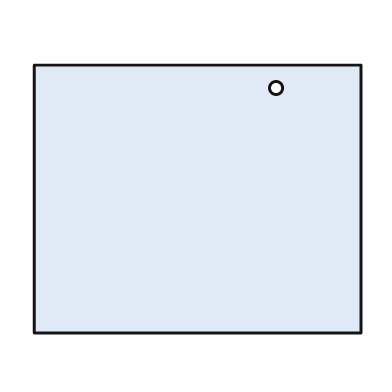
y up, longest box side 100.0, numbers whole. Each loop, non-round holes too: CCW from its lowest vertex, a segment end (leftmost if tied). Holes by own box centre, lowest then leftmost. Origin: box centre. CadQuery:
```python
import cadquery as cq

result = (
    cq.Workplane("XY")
    .moveTo(-50.0, -41.0)
    .lineTo(50.0, -41.0)
    .lineTo(50.0, 41.0)
    .lineTo(-50.0, 41.0)
    .close()
    .moveTo(24.0, 34.0)
    .circle(2.0)
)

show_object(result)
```